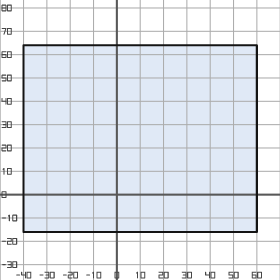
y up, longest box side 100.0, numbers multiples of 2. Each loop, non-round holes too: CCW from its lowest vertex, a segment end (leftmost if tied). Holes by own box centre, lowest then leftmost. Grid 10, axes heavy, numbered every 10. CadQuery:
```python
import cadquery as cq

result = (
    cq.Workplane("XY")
    .moveTo(-40.0, -16.0)
    .lineTo(60.0, -16.0)
    .lineTo(60.0, 64.0)
    .lineTo(-40.0, 64.0)
    .close()
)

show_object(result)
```